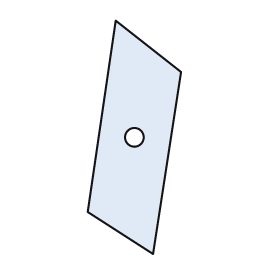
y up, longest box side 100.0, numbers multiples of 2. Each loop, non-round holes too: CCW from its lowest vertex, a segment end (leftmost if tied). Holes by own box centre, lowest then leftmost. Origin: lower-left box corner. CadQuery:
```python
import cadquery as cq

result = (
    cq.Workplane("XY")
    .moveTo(28.0, 0.0)
    .lineTo(40.0, 78.0)
    .lineTo(12.0, 100.0)
    .lineTo(0.0, 18.0)
    .close()
    .moveTo(20.0, 50.0)
    .circle(4.0)
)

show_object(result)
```